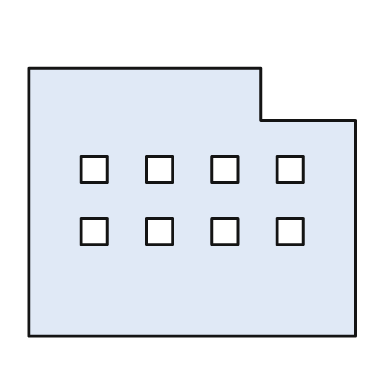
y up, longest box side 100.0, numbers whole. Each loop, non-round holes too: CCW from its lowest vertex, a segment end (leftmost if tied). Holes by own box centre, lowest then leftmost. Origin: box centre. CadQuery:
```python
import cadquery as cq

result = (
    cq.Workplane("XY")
    .moveTo(-50.0, -41.0)
    .lineTo(50.0, -41.0)
    .lineTo(50.0, 25.0)
    .lineTo(21.0, 25.0)
    .lineTo(21.0, 41.0)
    .lineTo(-50.0, 41.0)
    .close()
    .moveTo(-34.0, -13.0)
    .lineTo(-26.0, -13.0)
    .lineTo(-26.0, -5.0)
    .lineTo(-34.0, -5.0)
    .close()
    .moveTo(-14.0, -13.0)
    .lineTo(-6.0, -13.0)
    .lineTo(-6.0, -5.0)
    .lineTo(-14.0, -5.0)
    .close()
    .moveTo(6.0, -13.0)
    .lineTo(14.0, -13.0)
    .lineTo(14.0, -5.0)
    .lineTo(6.0, -5.0)
    .close()
    .moveTo(26.0, -13.0)
    .lineTo(34.0, -13.0)
    .lineTo(34.0, -5.0)
    .lineTo(26.0, -5.0)
    .close()
    .moveTo(-34.0, 6.0)
    .lineTo(-26.0, 6.0)
    .lineTo(-26.0, 14.0)
    .lineTo(-34.0, 14.0)
    .close()
    .moveTo(-14.0, 6.0)
    .lineTo(-6.0, 6.0)
    .lineTo(-6.0, 14.0)
    .lineTo(-14.0, 14.0)
    .close()
    .moveTo(6.0, 6.0)
    .lineTo(14.0, 6.0)
    .lineTo(14.0, 14.0)
    .lineTo(6.0, 14.0)
    .close()
    .moveTo(26.0, 6.0)
    .lineTo(34.0, 6.0)
    .lineTo(34.0, 14.0)
    .lineTo(26.0, 14.0)
    .close()
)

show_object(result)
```